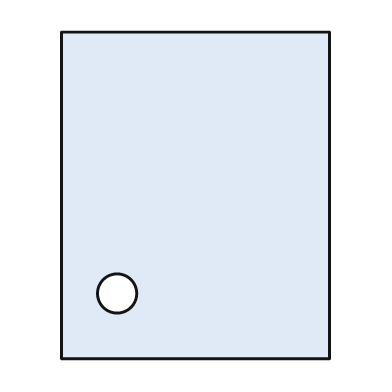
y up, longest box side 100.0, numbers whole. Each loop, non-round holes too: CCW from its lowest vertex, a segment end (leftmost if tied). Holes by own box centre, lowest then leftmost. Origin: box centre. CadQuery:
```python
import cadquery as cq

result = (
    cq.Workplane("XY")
    .moveTo(-41.0, -50.0)
    .lineTo(41.0, -50.0)
    .lineTo(41.0, 50.0)
    .lineTo(-41.0, 50.0)
    .close()
    .moveTo(-24.0, -30.0)
    .circle(6.0)
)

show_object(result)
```